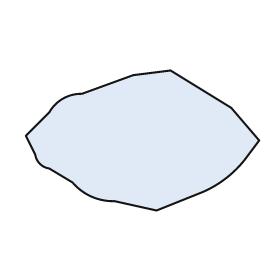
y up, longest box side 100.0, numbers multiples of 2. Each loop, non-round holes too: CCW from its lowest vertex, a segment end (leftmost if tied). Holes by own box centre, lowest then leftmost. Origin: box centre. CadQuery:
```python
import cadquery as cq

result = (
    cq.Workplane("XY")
    .moveTo(6.0, -30.0)
    .lineTo(26.0, -22.0)
    .threePointArc((36.0, -16.0), (44.0, -8.0))
    .lineTo(50.0, 0.0)
    .lineTo(38.0, 14.0)
    .lineTo(12.0, 30.0)
    .lineTo(-4.0, 28.0)
    .lineTo(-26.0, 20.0)
    .threePointArc((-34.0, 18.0), (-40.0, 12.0))
    .lineTo(-50.0, 2.0)
    .lineTo(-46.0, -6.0)
    .threePointArc((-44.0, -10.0), (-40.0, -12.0))
    .lineTo(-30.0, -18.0)
    .threePointArc((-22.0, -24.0), (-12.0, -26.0))
    .close()
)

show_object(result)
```